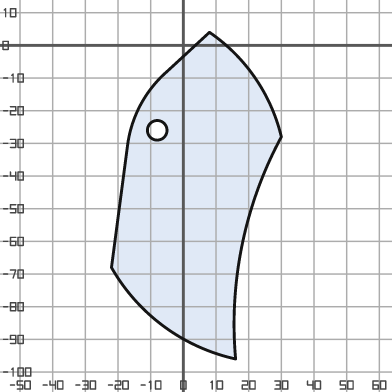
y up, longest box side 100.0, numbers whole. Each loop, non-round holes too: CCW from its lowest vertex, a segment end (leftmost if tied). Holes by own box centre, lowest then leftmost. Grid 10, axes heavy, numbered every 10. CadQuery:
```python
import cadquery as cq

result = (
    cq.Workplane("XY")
    .moveTo(16.0, -96.0)
    .threePointArc((18.0, -61.0), (30.0, -28.0))
    .threePointArc((22.0, -10.0), (8.0, 4.0))
    .lineTo(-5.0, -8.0)
    .threePointArc((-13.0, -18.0), (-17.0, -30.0))
    .lineTo(-22.0, -68.0)
    .threePointArc((-6.0, -86.0), (16.0, -96.0))
    .close()
    .moveTo(-8.0, -26.0)
    .circle(3.0)
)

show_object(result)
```